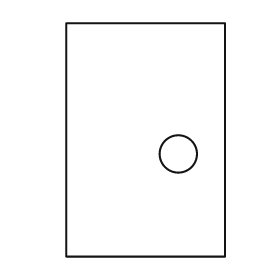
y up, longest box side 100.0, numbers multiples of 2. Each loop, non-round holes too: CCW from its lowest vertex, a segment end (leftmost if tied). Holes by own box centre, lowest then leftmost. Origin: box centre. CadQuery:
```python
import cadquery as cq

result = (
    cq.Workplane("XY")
    .moveTo(-34.0, -50.0)
    .lineTo(34.0, -50.0)
    .lineTo(34.0, 50.0)
    .lineTo(-34.0, 50.0)
    .close()
    .moveTo(14.0, -6.0)
    .circle(8.0)
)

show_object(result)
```